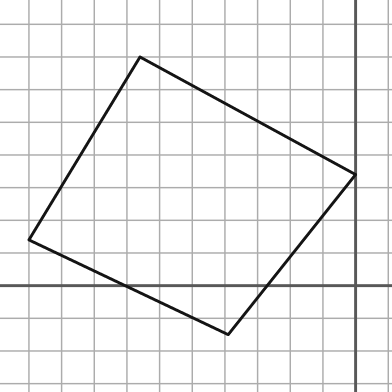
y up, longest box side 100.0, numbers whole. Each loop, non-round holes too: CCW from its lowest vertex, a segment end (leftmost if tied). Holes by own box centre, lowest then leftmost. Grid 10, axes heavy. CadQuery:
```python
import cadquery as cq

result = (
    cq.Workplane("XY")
    .moveTo(-39.0, -15.0)
    .lineTo(0.0, 34.0)
    .lineTo(-66.0, 70.0)
    .lineTo(-100.0, 14.0)
    .close()
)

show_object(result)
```